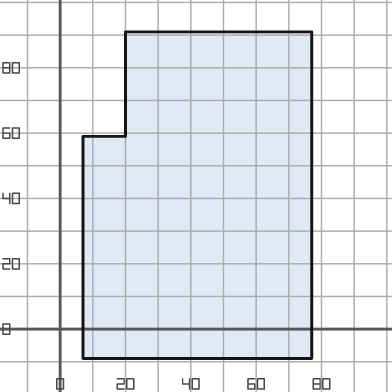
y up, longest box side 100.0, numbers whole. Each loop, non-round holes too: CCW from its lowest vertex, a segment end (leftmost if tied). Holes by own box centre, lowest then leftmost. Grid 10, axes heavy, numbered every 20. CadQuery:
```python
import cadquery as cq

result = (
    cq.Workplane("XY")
    .moveTo(7.0, -9.0)
    .lineTo(77.0, -9.0)
    .lineTo(77.0, 91.0)
    .lineTo(20.0, 91.0)
    .lineTo(20.0, 59.0)
    .lineTo(7.0, 59.0)
    .close()
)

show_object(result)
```